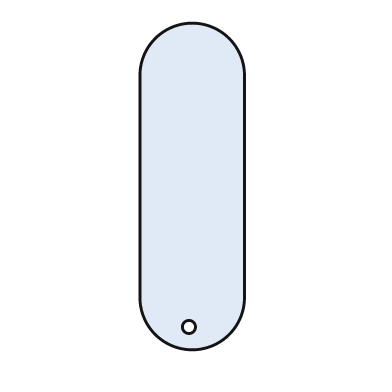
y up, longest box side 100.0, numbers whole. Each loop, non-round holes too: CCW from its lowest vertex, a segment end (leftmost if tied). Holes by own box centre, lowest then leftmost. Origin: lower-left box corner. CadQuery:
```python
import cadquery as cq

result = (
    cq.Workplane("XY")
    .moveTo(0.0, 16.0)
    .threePointArc((16.0, 0.0), (32.0, 16.0))
    .lineTo(32.0, 84.0)
    .threePointArc((16.0, 100.0), (0.0, 84.0))
    .close()
    .moveTo(15.0, 7.0)
    .circle(2.0)
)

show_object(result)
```